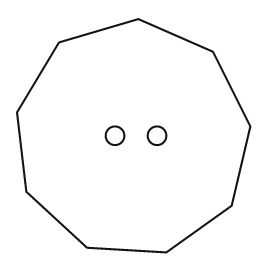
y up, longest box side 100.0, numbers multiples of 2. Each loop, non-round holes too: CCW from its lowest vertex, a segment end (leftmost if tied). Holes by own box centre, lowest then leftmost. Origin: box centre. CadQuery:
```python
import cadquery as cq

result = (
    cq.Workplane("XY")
    .moveTo(14.0, -50.0)
    .lineTo(42.0, -30.0)
    .lineTo(50.0, 4.0)
    .lineTo(34.0, 36.0)
    .lineTo(2.0, 50.0)
    .lineTo(-32.0, 40.0)
    .lineTo(-50.0, 10.0)
    .lineTo(-46.0, -24.0)
    .lineTo(-20.0, -48.0)
    .close()
    .moveTo(-8.0, 0.0)
    .circle(4.0)
    .moveTo(10.0, 0.0)
    .circle(4.0)
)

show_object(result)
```